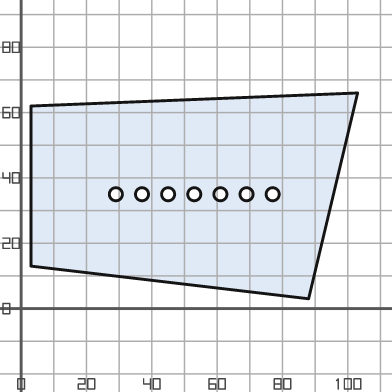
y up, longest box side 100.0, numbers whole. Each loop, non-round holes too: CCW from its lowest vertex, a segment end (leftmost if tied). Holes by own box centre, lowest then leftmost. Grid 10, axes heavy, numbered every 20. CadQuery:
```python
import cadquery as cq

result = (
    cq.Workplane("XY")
    .moveTo(88.0, 3.0)
    .lineTo(103.0, 66.0)
    .lineTo(3.0, 62.0)
    .lineTo(3.0, 13.0)
    .close()
    .moveTo(29.0, 35.0)
    .circle(2.0)
    .moveTo(37.0, 35.0)
    .circle(2.0)
    .moveTo(45.0, 35.0)
    .circle(2.0)
    .moveTo(53.0, 35.0)
    .circle(2.0)
    .moveTo(61.0, 35.0)
    .circle(2.0)
    .moveTo(69.0, 35.0)
    .circle(2.0)
    .moveTo(77.0, 35.0)
    .circle(2.0)
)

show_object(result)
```